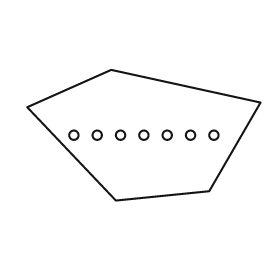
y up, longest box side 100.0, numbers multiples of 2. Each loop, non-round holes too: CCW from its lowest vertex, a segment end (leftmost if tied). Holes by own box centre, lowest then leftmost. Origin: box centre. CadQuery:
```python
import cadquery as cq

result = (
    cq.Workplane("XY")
    .moveTo(-12.0, -28.0)
    .lineTo(28.0, -24.0)
    .lineTo(50.0, 14.0)
    .lineTo(-14.0, 28.0)
    .lineTo(-50.0, 12.0)
    .close()
    .moveTo(-30.0, 0.0)
    .circle(2.0)
    .moveTo(-20.0, 0.0)
    .circle(2.0)
    .moveTo(-10.0, 0.0)
    .circle(2.0)
    .moveTo(0.0, 0.0)
    .circle(2.0)
    .moveTo(10.0, 0.0)
    .circle(2.0)
    .moveTo(20.0, 0.0)
    .circle(2.0)
    .moveTo(30.0, 0.0)
    .circle(2.0)
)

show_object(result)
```